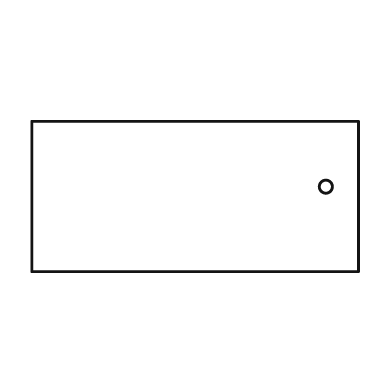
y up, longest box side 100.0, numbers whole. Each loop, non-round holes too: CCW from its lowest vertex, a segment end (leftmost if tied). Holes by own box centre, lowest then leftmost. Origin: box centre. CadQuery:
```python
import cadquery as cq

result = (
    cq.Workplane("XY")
    .moveTo(-50.0, -23.0)
    .lineTo(50.0, -23.0)
    .lineTo(50.0, 23.0)
    .lineTo(-50.0, 23.0)
    .close()
    .moveTo(40.0, 3.0)
    .circle(2.0)
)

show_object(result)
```